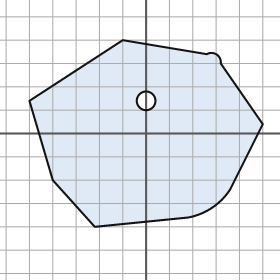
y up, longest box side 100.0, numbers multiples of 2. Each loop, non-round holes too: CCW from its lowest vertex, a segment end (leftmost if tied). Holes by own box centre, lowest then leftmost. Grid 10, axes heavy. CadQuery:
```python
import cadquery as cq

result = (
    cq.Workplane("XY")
    .moveTo(-22.0, -40.0)
    .lineTo(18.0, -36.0)
    .threePointArc((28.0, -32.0), (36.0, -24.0))
    .lineTo(50.0, 4.0)
    .lineTo(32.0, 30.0)
    .threePointArc((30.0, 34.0), (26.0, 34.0))
    .lineTo(-10.0, 40.0)
    .lineTo(-50.0, 14.0)
    .lineTo(-40.0, -20.0)
    .close()
    .moveTo(0.0, 14.0)
    .circle(4.0)
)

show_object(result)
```